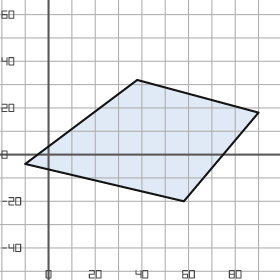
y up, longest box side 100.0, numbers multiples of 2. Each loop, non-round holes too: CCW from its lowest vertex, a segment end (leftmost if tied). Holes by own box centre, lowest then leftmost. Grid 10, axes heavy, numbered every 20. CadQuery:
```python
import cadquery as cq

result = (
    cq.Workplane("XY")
    .moveTo(58.0, -20.0)
    .lineTo(90.0, 18.0)
    .lineTo(38.0, 32.0)
    .lineTo(-10.0, -4.0)
    .close()
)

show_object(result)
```